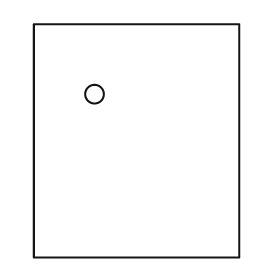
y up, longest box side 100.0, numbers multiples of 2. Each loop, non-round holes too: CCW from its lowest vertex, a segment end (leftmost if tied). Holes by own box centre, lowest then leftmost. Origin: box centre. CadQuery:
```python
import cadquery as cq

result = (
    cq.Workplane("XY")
    .moveTo(-44.0, -50.0)
    .lineTo(44.0, -50.0)
    .lineTo(44.0, 50.0)
    .lineTo(-44.0, 50.0)
    .close()
    .moveTo(-18.0, 20.0)
    .circle(4.0)
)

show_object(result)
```